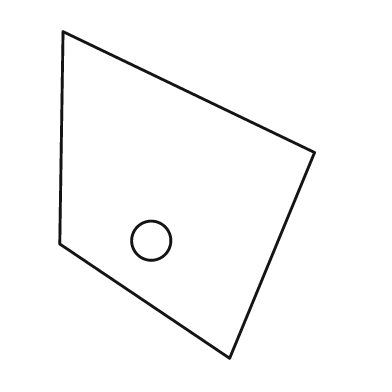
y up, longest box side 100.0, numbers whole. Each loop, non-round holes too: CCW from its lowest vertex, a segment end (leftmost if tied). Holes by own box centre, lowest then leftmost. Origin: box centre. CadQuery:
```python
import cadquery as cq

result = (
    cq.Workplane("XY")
    .moveTo(13.0, -50.0)
    .lineTo(39.0, 13.0)
    .lineTo(-38.0, 50.0)
    .lineTo(-39.0, -15.0)
    .close()
    .moveTo(-11.0, -14.0)
    .circle(6.0)
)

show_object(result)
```